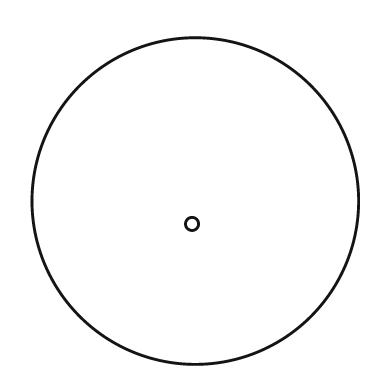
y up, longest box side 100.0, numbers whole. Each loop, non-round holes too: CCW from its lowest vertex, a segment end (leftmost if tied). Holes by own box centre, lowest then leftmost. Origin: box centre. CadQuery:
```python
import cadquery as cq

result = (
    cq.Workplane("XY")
    .moveTo(0.0, 0.0)
    .circle(50.0)
    .moveTo(-1.0, -7.0)
    .circle(2.0)
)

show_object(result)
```